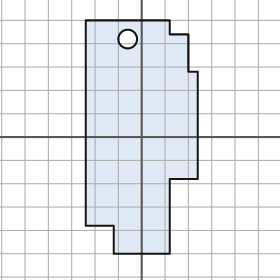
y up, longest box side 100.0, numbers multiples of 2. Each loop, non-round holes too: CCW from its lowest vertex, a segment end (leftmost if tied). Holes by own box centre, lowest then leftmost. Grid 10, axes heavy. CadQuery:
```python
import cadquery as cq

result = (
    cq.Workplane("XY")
    .moveTo(-12.0, -50.0)
    .lineTo(12.0, -50.0)
    .lineTo(12.0, -18.0)
    .lineTo(24.0, -18.0)
    .lineTo(24.0, 28.0)
    .lineTo(20.0, 28.0)
    .lineTo(20.0, 44.0)
    .lineTo(12.0, 44.0)
    .lineTo(12.0, 50.0)
    .lineTo(-24.0, 50.0)
    .lineTo(-24.0, -38.0)
    .lineTo(-12.0, -38.0)
    .close()
    .moveTo(-6.0, 42.0)
    .circle(4.0)
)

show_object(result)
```